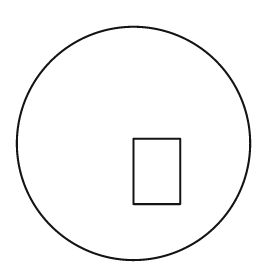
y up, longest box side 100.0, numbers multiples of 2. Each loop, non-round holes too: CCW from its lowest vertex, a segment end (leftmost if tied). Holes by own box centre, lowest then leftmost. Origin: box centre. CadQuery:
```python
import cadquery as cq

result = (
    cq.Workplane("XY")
    .moveTo(0.0, 0.0)
    .circle(50.0)
    .moveTo(0.0, -26.0)
    .lineTo(20.0, -26.0)
    .lineTo(20.0, 2.0)
    .lineTo(0.0, 2.0)
    .close()
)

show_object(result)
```